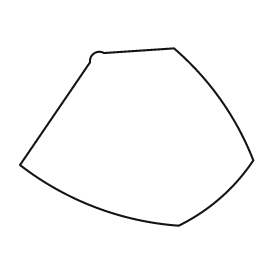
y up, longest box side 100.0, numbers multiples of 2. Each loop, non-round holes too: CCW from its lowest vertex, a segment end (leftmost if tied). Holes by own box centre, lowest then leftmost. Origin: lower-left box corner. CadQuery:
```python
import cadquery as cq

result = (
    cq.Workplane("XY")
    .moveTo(68.0, 0.0)
    .threePointArc((86.0, 12.0), (100.0, 28.0))
    .threePointArc((86.0, 54.0), (66.0, 76.0))
    .lineTo(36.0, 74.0)
    .threePointArc((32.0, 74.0), (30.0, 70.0))
    .lineTo(0.0, 26.0)
    .threePointArc((32.0, 8.0), (68.0, 0.0))
    .close()
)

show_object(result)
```